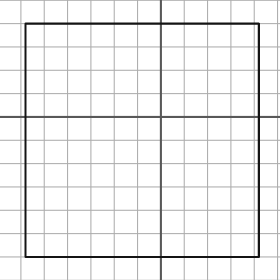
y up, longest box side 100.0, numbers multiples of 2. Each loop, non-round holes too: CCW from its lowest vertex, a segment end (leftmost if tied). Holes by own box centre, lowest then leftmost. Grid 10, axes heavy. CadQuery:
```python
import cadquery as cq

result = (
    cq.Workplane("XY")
    .moveTo(-58.0, -60.0)
    .lineTo(42.0, -60.0)
    .lineTo(42.0, 40.0)
    .lineTo(-58.0, 40.0)
    .close()
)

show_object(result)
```